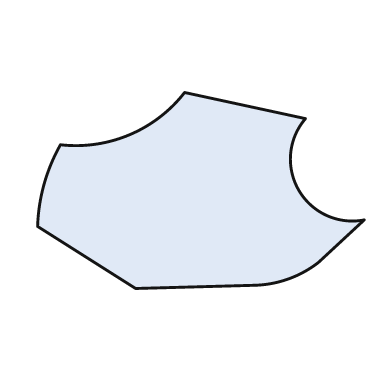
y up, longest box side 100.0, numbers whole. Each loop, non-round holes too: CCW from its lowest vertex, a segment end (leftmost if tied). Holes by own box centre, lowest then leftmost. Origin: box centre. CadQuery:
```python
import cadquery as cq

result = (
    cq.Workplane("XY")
    .moveTo(-20.0, -30.0)
    .lineTo(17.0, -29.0)
    .threePointArc((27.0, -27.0), (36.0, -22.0))
    .lineTo(50.0, -9.0)
    .threePointArc((30.0, 0.0), (32.0, 22.0))
    .lineTo(-5.0, 30.0)
    .threePointArc((-22.0, 17.0), (-43.0, 14.0))
    .threePointArc((-48.0, 2.0), (-50.0, -11.0))
    .close()
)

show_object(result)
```